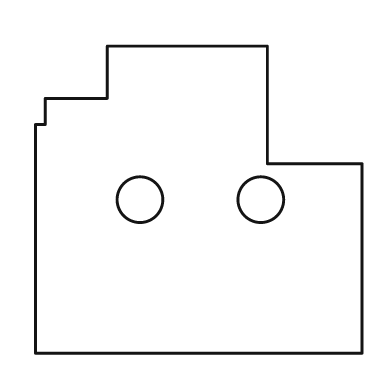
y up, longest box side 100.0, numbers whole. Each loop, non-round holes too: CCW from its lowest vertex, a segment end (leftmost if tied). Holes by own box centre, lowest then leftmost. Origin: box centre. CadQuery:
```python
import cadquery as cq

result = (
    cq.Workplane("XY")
    .moveTo(-50.0, -47.0)
    .lineTo(50.0, -47.0)
    .lineTo(50.0, 11.0)
    .lineTo(21.0, 11.0)
    .lineTo(21.0, 47.0)
    .lineTo(-28.0, 47.0)
    .lineTo(-28.0, 31.0)
    .lineTo(-47.0, 31.0)
    .lineTo(-47.0, 23.0)
    .lineTo(-50.0, 23.0)
    .close()
    .moveTo(-18.0, 0.0)
    .circle(7.0)
    .moveTo(19.0, 0.0)
    .circle(7.0)
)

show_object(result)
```